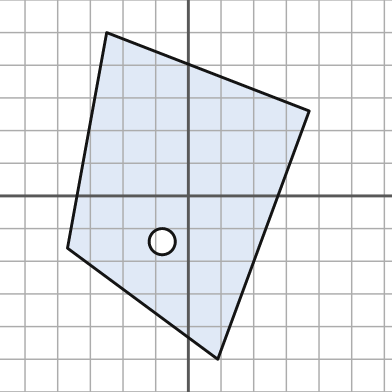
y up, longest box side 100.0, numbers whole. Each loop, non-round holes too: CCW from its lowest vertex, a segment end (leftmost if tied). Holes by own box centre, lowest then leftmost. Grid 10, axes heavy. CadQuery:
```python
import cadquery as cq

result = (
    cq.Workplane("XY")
    .moveTo(9.0, -50.0)
    .lineTo(37.0, 26.0)
    .lineTo(-25.0, 50.0)
    .lineTo(-37.0, -16.0)
    .close()
    .moveTo(-8.0, -14.0)
    .circle(4.0)
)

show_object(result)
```